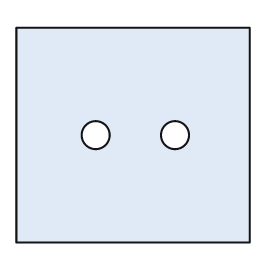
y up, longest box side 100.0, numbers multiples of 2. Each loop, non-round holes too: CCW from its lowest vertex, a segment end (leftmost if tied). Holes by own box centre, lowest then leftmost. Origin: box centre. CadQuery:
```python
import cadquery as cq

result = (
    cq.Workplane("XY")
    .moveTo(-50.0, -46.0)
    .lineTo(50.0, -46.0)
    .lineTo(50.0, 46.0)
    .lineTo(-50.0, 46.0)
    .close()
    .moveTo(-16.0, 0.0)
    .circle(6.0)
    .moveTo(18.0, 0.0)
    .circle(6.0)
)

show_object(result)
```